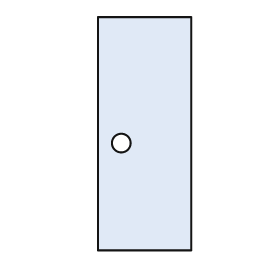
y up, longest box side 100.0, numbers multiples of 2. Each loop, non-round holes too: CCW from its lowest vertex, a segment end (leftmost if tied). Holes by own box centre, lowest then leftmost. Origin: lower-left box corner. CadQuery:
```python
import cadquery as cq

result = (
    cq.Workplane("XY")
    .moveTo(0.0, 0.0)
    .lineTo(40.0, 0.0)
    .lineTo(40.0, 100.0)
    .lineTo(0.0, 100.0)
    .close()
    .moveTo(10.0, 46.0)
    .circle(4.0)
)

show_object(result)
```